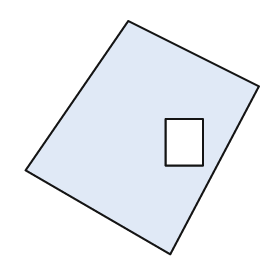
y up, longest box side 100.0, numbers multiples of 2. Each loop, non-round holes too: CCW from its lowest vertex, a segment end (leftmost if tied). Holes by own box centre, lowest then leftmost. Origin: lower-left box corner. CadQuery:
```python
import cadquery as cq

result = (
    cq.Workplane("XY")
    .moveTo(62.0, 0.0)
    .lineTo(100.0, 72.0)
    .lineTo(44.0, 100.0)
    .lineTo(0.0, 36.0)
    .close()
    .moveTo(60.0, 38.0)
    .lineTo(76.0, 38.0)
    .lineTo(76.0, 58.0)
    .lineTo(60.0, 58.0)
    .close()
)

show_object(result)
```